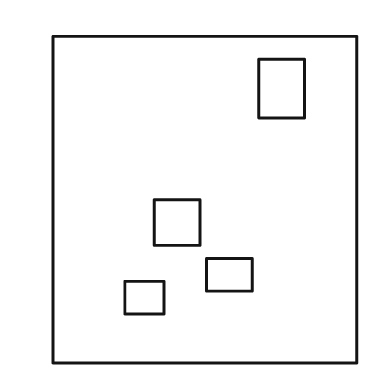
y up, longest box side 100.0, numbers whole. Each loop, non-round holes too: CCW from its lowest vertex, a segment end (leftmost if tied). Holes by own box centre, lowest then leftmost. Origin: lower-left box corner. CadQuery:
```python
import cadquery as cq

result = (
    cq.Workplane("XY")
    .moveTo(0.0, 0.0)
    .lineTo(93.0, 0.0)
    .lineTo(93.0, 100.0)
    .lineTo(0.0, 100.0)
    .close()
    .moveTo(22.0, 15.0)
    .lineTo(34.0, 15.0)
    .lineTo(34.0, 25.0)
    .lineTo(22.0, 25.0)
    .close()
    .moveTo(47.0, 22.0)
    .lineTo(61.0, 22.0)
    .lineTo(61.0, 32.0)
    .lineTo(47.0, 32.0)
    .close()
    .moveTo(31.0, 36.0)
    .lineTo(45.0, 36.0)
    .lineTo(45.0, 50.0)
    .lineTo(31.0, 50.0)
    .close()
    .moveTo(63.0, 75.0)
    .lineTo(77.0, 75.0)
    .lineTo(77.0, 93.0)
    .lineTo(63.0, 93.0)
    .close()
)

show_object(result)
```